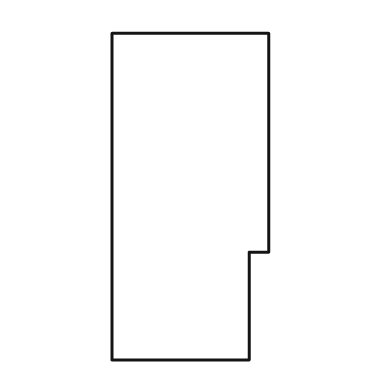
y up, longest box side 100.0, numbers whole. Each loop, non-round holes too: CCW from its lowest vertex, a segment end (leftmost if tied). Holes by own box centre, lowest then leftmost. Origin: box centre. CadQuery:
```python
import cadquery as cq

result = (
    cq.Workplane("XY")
    .moveTo(-24.0, -50.0)
    .lineTo(18.0, -50.0)
    .lineTo(18.0, -17.0)
    .lineTo(24.0, -17.0)
    .lineTo(24.0, 50.0)
    .lineTo(-24.0, 50.0)
    .close()
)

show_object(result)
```